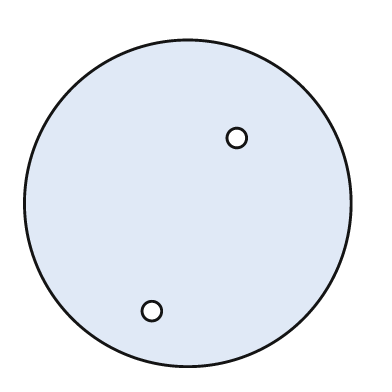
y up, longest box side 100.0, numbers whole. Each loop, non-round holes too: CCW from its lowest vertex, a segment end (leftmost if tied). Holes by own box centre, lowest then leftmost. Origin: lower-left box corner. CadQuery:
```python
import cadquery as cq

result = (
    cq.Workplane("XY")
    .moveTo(50.0, 50.0)
    .circle(50.0)
    .moveTo(39.0, 17.0)
    .circle(3.0)
    .moveTo(65.0, 70.0)
    .circle(3.0)
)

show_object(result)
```